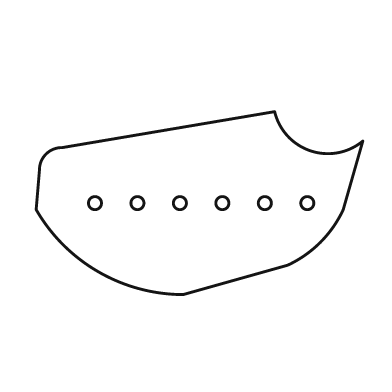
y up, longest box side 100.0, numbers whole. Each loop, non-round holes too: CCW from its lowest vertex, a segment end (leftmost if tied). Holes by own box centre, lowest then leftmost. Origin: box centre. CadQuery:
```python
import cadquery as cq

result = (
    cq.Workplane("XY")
    .moveTo(-5.0, -28.0)
    .lineTo(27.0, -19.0)
    .threePointArc((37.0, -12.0), (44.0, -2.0))
    .lineTo(50.0, 19.0)
    .threePointArc((34.0, 16.0), (23.0, 28.0))
    .lineTo(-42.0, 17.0)
    .threePointArc((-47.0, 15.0), (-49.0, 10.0))
    .lineTo(-50.0, -2.0)
    .threePointArc((-31.0, -21.0), (-5.0, -28.0))
    .close()
    .moveTo(-32.0, 0.0)
    .circle(2.0)
    .moveTo(-19.0, 0.0)
    .circle(2.0)
    .moveTo(-6.0, 0.0)
    .circle(2.0)
    .moveTo(7.0, 0.0)
    .circle(2.0)
    .moveTo(20.0, 0.0)
    .circle(2.0)
    .moveTo(33.0, 0.0)
    .circle(2.0)
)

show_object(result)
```